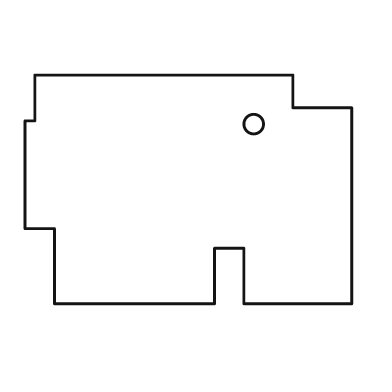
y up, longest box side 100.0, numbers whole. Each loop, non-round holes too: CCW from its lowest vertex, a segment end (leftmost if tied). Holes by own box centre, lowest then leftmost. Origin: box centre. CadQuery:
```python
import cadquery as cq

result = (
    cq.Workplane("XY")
    .moveTo(-41.0, -35.0)
    .lineTo(8.0, -35.0)
    .lineTo(8.0, -18.0)
    .lineTo(17.0, -18.0)
    .lineTo(17.0, -35.0)
    .lineTo(50.0, -35.0)
    .lineTo(50.0, 25.0)
    .lineTo(32.0, 25.0)
    .lineTo(32.0, 35.0)
    .lineTo(-47.0, 35.0)
    .lineTo(-47.0, 21.0)
    .lineTo(-50.0, 21.0)
    .lineTo(-50.0, -12.0)
    .lineTo(-41.0, -12.0)
    .close()
    .moveTo(20.0, 20.0)
    .circle(3.0)
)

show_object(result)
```